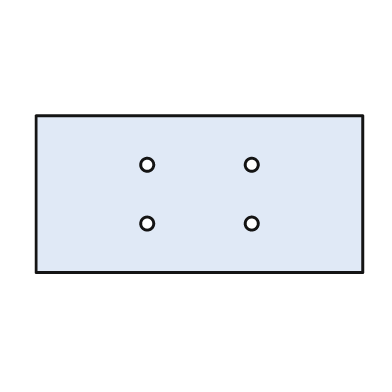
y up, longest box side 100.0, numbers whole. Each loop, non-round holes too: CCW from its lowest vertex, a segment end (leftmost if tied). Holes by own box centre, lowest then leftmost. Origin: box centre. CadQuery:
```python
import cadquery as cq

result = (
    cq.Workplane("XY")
    .moveTo(-50.0, -24.0)
    .lineTo(50.0, -24.0)
    .lineTo(50.0, 24.0)
    .lineTo(-50.0, 24.0)
    .close()
    .moveTo(-16.0, -9.0)
    .circle(2.0)
    .moveTo(16.0, -9.0)
    .circle(2.0)
    .moveTo(-16.0, 9.0)
    .circle(2.0)
    .moveTo(16.0, 9.0)
    .circle(2.0)
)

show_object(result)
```